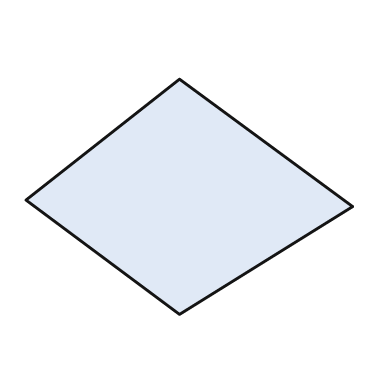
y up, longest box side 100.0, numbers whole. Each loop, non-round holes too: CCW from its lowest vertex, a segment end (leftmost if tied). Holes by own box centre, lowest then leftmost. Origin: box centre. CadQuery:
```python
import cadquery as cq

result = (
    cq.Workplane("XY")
    .moveTo(-3.0, -36.0)
    .lineTo(50.0, -3.0)
    .lineTo(-3.0, 36.0)
    .lineTo(-50.0, -1.0)
    .close()
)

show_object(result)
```